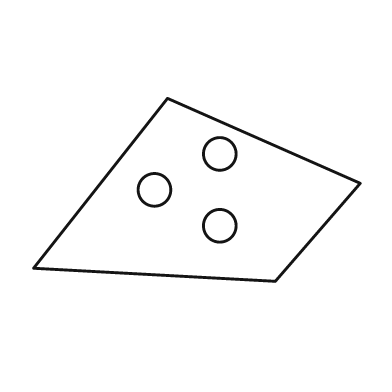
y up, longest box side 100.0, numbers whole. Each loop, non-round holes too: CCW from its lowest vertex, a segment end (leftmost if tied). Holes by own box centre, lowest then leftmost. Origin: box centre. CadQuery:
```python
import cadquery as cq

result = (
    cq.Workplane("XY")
    .moveTo(24.0, -28.0)
    .lineTo(50.0, 2.0)
    .lineTo(-9.0, 28.0)
    .lineTo(-50.0, -24.0)
    .close()
    .moveTo(7.0, -11.0)
    .circle(5.0)
    .moveTo(-13.0, 0.0)
    .circle(5.0)
    .moveTo(7.0, 11.0)
    .circle(5.0)
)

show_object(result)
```